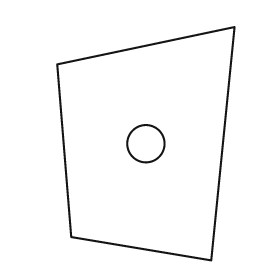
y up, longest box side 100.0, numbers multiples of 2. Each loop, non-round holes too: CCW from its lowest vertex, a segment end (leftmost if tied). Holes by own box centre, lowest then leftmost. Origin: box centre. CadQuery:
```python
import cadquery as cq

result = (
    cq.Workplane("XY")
    .moveTo(28.0, -50.0)
    .lineTo(38.0, 50.0)
    .lineTo(-38.0, 34.0)
    .lineTo(-32.0, -40.0)
    .close()
    .moveTo(0.0, 0.0)
    .circle(8.0)
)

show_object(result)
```